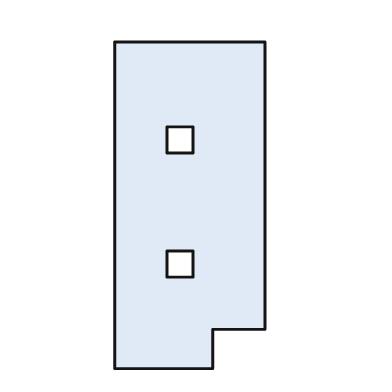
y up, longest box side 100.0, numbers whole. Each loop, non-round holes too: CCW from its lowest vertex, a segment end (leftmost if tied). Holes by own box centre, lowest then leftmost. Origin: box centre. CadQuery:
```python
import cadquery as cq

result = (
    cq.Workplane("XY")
    .moveTo(-23.0, -50.0)
    .lineTo(7.0, -50.0)
    .lineTo(7.0, -38.0)
    .lineTo(23.0, -38.0)
    .lineTo(23.0, 50.0)
    .lineTo(-23.0, 50.0)
    .close()
    .moveTo(-7.0, -22.0)
    .lineTo(1.0, -22.0)
    .lineTo(1.0, -14.0)
    .lineTo(-7.0, -14.0)
    .close()
    .moveTo(-7.0, 16.0)
    .lineTo(1.0, 16.0)
    .lineTo(1.0, 24.0)
    .lineTo(-7.0, 24.0)
    .close()
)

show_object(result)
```